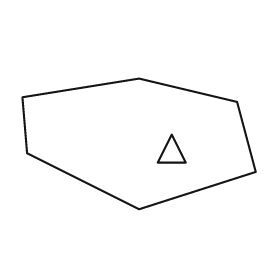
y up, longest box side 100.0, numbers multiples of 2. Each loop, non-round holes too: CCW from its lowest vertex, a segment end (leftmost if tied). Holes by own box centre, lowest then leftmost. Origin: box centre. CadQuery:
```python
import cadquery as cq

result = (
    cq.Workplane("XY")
    .moveTo(0.0, -28.0)
    .lineTo(50.0, -12.0)
    .lineTo(42.0, 18.0)
    .lineTo(0.0, 28.0)
    .lineTo(-50.0, 20.0)
    .lineTo(-48.0, -4.0)
    .close()
    .moveTo(8.0, -8.0)
    .lineTo(20.0, -8.0)
    .lineTo(14.0, 4.0)
    .close()
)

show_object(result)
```